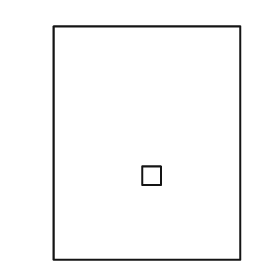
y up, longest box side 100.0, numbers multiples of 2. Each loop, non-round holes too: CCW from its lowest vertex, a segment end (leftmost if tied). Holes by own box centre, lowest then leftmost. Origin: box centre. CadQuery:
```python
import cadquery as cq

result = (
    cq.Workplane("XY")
    .moveTo(-40.0, -50.0)
    .lineTo(40.0, -50.0)
    .lineTo(40.0, 50.0)
    .lineTo(-40.0, 50.0)
    .close()
    .moveTo(-2.0, -18.0)
    .lineTo(6.0, -18.0)
    .lineTo(6.0, -10.0)
    .lineTo(-2.0, -10.0)
    .close()
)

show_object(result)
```